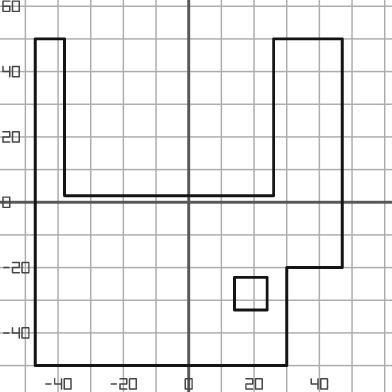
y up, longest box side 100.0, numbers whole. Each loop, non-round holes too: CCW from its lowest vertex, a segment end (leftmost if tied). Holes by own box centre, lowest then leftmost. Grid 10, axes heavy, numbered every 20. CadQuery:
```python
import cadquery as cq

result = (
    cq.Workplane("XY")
    .moveTo(-47.0, -50.0)
    .lineTo(30.0, -50.0)
    .lineTo(30.0, -20.0)
    .lineTo(47.0, -20.0)
    .lineTo(47.0, 50.0)
    .lineTo(26.0, 50.0)
    .lineTo(26.0, 2.0)
    .lineTo(-38.0, 2.0)
    .lineTo(-38.0, 50.0)
    .lineTo(-47.0, 50.0)
    .close()
    .moveTo(14.0, -33.0)
    .lineTo(24.0, -33.0)
    .lineTo(24.0, -23.0)
    .lineTo(14.0, -23.0)
    .close()
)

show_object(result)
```